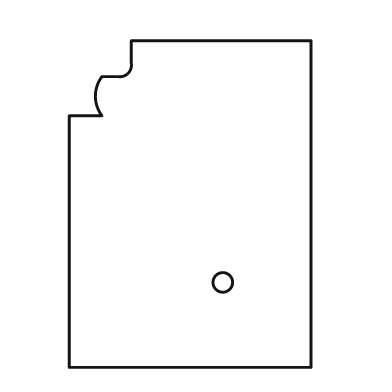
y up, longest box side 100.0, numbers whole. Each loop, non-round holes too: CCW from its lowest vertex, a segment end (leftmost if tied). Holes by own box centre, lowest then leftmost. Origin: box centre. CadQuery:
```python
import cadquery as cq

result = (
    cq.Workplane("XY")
    .moveTo(-37.0, -50.0)
    .lineTo(37.0, -50.0)
    .lineTo(37.0, 50.0)
    .lineTo(-18.0, 50.0)
    .lineTo(-18.0, 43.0)
    .threePointArc((-19.0, 40.0), (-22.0, 39.0))
    .lineTo(-27.0, 39.0)
    .threePointArc((-29.0, 33.0), (-27.0, 27.0))
    .lineTo(-37.0, 27.0)
    .close()
    .moveTo(10.0, -24.0)
    .circle(3.0)
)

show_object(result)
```